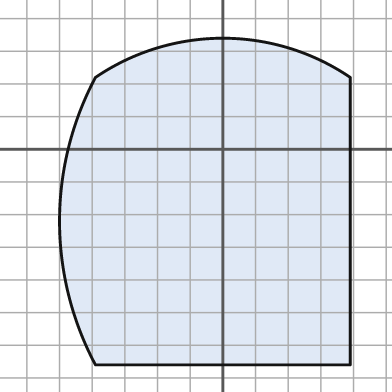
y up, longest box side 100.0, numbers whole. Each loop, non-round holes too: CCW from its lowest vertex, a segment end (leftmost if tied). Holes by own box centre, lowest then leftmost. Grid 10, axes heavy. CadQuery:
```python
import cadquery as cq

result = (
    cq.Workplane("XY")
    .moveTo(-39.0, -66.0)
    .lineTo(39.0, -66.0)
    .lineTo(39.0, 22.0)
    .threePointArc((0.0, 34.0), (-39.0, 22.0))
    .threePointArc((-50.0, -22.0), (-39.0, -66.0))
    .close()
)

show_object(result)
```